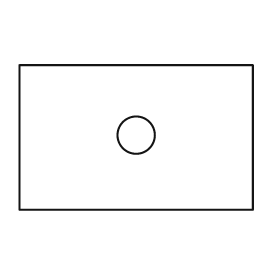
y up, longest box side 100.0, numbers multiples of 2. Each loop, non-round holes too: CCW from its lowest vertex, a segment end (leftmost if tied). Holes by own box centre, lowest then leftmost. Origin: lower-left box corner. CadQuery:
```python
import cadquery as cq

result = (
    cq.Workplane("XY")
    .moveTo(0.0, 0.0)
    .lineTo(100.0, 0.0)
    .lineTo(100.0, 62.0)
    .lineTo(0.0, 62.0)
    .close()
    .moveTo(50.0, 32.0)
    .circle(8.0)
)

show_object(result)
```